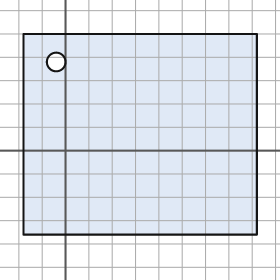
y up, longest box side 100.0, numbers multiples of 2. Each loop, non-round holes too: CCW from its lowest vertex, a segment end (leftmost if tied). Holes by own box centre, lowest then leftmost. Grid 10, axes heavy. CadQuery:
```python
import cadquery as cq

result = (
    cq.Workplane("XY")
    .moveTo(-18.0, -36.0)
    .lineTo(82.0, -36.0)
    .lineTo(82.0, 50.0)
    .lineTo(-18.0, 50.0)
    .close()
    .moveTo(-4.0, 38.0)
    .circle(4.0)
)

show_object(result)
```